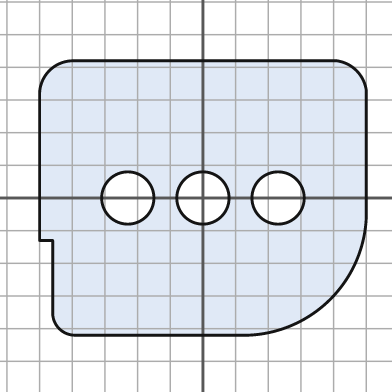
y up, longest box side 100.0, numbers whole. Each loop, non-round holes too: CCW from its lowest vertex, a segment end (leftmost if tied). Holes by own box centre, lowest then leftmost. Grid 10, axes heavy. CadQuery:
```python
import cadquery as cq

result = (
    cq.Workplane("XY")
    .moveTo(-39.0, -42.0)
    .lineTo(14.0, -42.0)
    .threePointArc((39.0, -31.0), (50.0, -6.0))
    .lineTo(50.0, 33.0)
    .threePointArc((47.0, 39.0), (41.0, 42.0))
    .lineTo(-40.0, 42.0)
    .threePointArc((-47.0, 39.0), (-50.0, 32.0))
    .lineTo(-50.0, -13.0)
    .lineTo(-46.0, -13.0)
    .lineTo(-46.0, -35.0)
    .threePointArc((-44.0, -40.0), (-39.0, -42.0))
    .close()
    .moveTo(-23.0, 0.0)
    .circle(8.0)
    .moveTo(0.0, 0.0)
    .circle(8.0)
    .moveTo(23.0, 0.0)
    .circle(8.0)
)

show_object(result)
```